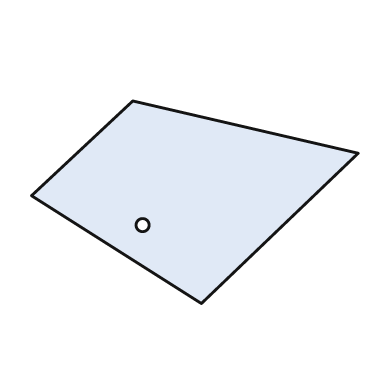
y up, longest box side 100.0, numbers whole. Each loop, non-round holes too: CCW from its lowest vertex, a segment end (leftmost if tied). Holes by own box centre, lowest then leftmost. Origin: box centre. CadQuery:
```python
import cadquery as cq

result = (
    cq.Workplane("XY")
    .moveTo(2.0, -31.0)
    .lineTo(50.0, 15.0)
    .lineTo(-19.0, 31.0)
    .lineTo(-50.0, 2.0)
    .close()
    .moveTo(-16.0, -7.0)
    .circle(2.0)
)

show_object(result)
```